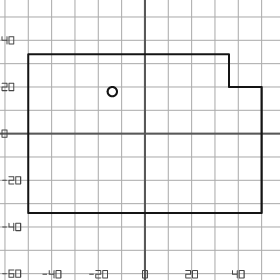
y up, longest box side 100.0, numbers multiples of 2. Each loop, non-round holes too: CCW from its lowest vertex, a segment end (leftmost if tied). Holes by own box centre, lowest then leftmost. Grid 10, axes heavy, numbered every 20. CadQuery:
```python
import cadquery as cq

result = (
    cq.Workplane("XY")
    .moveTo(-50.0, -34.0)
    .lineTo(50.0, -34.0)
    .lineTo(50.0, 20.0)
    .lineTo(36.0, 20.0)
    .lineTo(36.0, 34.0)
    .lineTo(-50.0, 34.0)
    .close()
    .moveTo(-14.0, 18.0)
    .circle(2.0)
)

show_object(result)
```